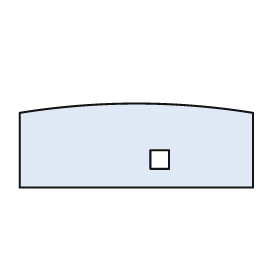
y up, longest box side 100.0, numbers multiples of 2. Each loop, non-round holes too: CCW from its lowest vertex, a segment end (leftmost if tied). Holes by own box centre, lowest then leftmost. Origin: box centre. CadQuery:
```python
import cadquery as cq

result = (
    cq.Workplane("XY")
    .moveTo(-50.0, -18.0)
    .lineTo(50.0, -18.0)
    .lineTo(50.0, 14.0)
    .threePointArc((0.0, 18.0), (-50.0, 14.0))
    .close()
    .moveTo(6.0, -10.0)
    .lineTo(14.0, -10.0)
    .lineTo(14.0, -2.0)
    .lineTo(6.0, -2.0)
    .close()
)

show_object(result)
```